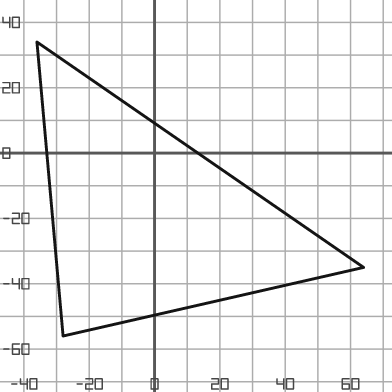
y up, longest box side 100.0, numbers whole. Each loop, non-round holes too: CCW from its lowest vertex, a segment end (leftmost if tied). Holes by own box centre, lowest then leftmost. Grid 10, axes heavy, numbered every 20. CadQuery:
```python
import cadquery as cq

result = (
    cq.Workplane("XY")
    .moveTo(-28.0, -56.0)
    .lineTo(64.0, -35.0)
    .lineTo(-36.0, 34.0)
    .close()
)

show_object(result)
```